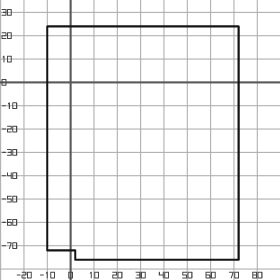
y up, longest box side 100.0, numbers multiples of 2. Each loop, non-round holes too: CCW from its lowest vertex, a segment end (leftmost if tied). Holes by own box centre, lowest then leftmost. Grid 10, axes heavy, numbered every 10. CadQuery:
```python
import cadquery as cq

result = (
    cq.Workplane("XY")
    .moveTo(2.0, -76.0)
    .lineTo(72.0, -76.0)
    .lineTo(72.0, 24.0)
    .lineTo(-10.0, 24.0)
    .lineTo(-10.0, -72.0)
    .lineTo(2.0, -72.0)
    .close()
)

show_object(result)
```